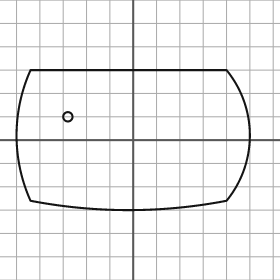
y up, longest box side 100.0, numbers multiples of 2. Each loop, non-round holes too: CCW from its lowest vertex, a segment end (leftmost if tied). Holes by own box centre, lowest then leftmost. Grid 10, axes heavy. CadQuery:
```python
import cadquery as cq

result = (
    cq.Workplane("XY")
    .moveTo(-44.0, -26.0)
    .threePointArc((-2.0, -30.0), (40.0, -26.0))
    .threePointArc((50.0, 2.0), (40.0, 30.0))
    .lineTo(-44.0, 30.0)
    .threePointArc((-50.0, 2.0), (-44.0, -26.0))
    .close()
    .moveTo(-28.0, 10.0)
    .circle(2.0)
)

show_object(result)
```